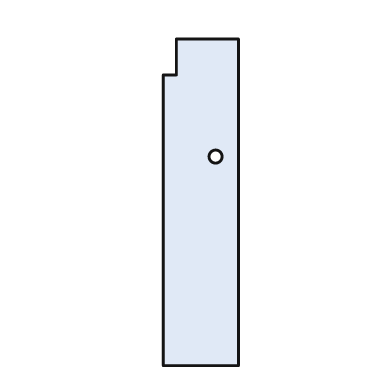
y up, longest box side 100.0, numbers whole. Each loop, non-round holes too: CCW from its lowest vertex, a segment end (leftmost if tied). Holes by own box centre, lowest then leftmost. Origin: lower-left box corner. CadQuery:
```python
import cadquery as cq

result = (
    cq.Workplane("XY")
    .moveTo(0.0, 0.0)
    .lineTo(23.0, 0.0)
    .lineTo(23.0, 100.0)
    .lineTo(4.0, 100.0)
    .lineTo(4.0, 89.0)
    .lineTo(0.0, 89.0)
    .close()
    .moveTo(16.0, 64.0)
    .circle(2.0)
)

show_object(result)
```